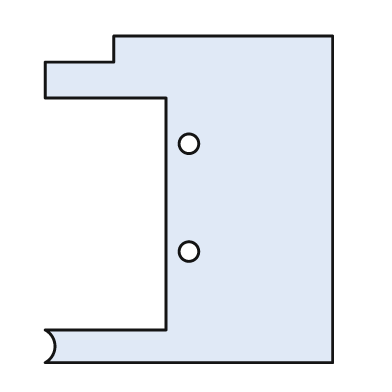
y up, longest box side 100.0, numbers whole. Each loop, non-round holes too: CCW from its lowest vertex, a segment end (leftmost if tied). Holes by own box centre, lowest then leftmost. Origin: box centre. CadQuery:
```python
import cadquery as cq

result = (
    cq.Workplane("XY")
    .moveTo(-44.0, -50.0)
    .lineTo(44.0, -50.0)
    .lineTo(44.0, 50.0)
    .lineTo(-23.0, 50.0)
    .lineTo(-23.0, 42.0)
    .lineTo(-44.0, 42.0)
    .lineTo(-44.0, 31.0)
    .lineTo(-7.0, 31.0)
    .lineTo(-7.0, -40.0)
    .lineTo(-44.0, -40.0)
    .threePointArc((-41.0, -45.0), (-44.0, -50.0))
    .close()
    .moveTo(0.0, -16.0)
    .circle(3.0)
    .moveTo(0.0, 17.0)
    .circle(3.0)
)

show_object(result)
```